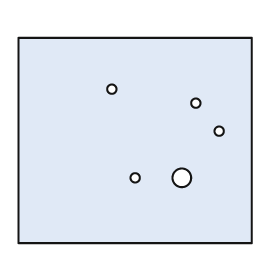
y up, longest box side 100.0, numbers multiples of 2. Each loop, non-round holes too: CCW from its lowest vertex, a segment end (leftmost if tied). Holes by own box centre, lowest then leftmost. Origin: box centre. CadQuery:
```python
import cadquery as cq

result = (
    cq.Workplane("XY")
    .moveTo(-50.0, -44.0)
    .lineTo(50.0, -44.0)
    .lineTo(50.0, 44.0)
    .lineTo(-50.0, 44.0)
    .close()
    .moveTo(0.0, -16.0)
    .circle(2.0)
    .moveTo(20.0, -16.0)
    .circle(4.0)
    .moveTo(36.0, 4.0)
    .circle(2.0)
    .moveTo(26.0, 16.0)
    .circle(2.0)
    .moveTo(-10.0, 22.0)
    .circle(2.0)
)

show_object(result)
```